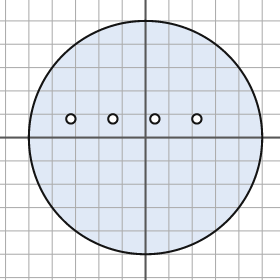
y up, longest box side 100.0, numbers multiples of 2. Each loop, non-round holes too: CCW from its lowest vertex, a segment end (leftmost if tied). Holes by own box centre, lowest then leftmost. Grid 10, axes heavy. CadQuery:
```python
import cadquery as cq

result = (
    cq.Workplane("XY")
    .moveTo(0.0, 0.0)
    .circle(50.0)
    .moveTo(-32.0, 8.0)
    .circle(2.0)
    .moveTo(-14.0, 8.0)
    .circle(2.0)
    .moveTo(4.0, 8.0)
    .circle(2.0)
    .moveTo(22.0, 8.0)
    .circle(2.0)
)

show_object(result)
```